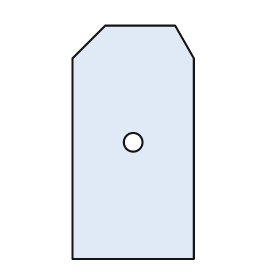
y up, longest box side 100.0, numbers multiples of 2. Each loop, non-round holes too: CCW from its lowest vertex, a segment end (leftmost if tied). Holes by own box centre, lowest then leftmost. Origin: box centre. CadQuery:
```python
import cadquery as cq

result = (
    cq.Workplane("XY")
    .moveTo(-26.0, -50.0)
    .lineTo(26.0, -50.0)
    .lineTo(26.0, 36.0)
    .lineTo(18.0, 50.0)
    .lineTo(-12.0, 50.0)
    .lineTo(-26.0, 36.0)
    .close()
    .moveTo(0.0, 0.0)
    .circle(4.0)
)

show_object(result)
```